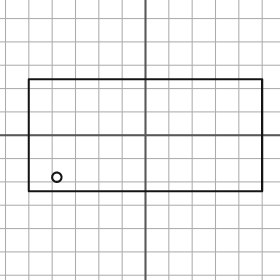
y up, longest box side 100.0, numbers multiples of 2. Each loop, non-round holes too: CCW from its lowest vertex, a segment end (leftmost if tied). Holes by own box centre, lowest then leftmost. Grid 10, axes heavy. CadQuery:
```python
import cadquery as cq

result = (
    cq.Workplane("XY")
    .moveTo(-50.0, -24.0)
    .lineTo(50.0, -24.0)
    .lineTo(50.0, 24.0)
    .lineTo(-50.0, 24.0)
    .close()
    .moveTo(-38.0, -18.0)
    .circle(2.0)
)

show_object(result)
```